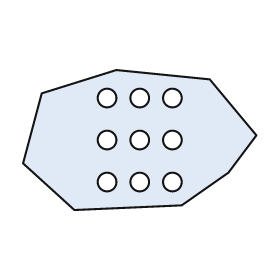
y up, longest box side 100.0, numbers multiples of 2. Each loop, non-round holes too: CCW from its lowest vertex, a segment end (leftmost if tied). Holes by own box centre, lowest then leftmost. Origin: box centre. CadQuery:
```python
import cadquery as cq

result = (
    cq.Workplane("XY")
    .moveTo(-28.0, -30.0)
    .lineTo(18.0, -28.0)
    .lineTo(38.0, -14.0)
    .lineTo(50.0, 2.0)
    .lineTo(30.0, 26.0)
    .lineTo(-10.0, 30.0)
    .lineTo(-42.0, 20.0)
    .lineTo(-50.0, -10.0)
    .close()
    .moveTo(-14.0, -18.0)
    .circle(4.0)
    .moveTo(0.0, -18.0)
    .circle(4.0)
    .moveTo(14.0, -18.0)
    .circle(4.0)
    .moveTo(-14.0, 0.0)
    .circle(4.0)
    .moveTo(0.0, 0.0)
    .circle(4.0)
    .moveTo(14.0, 0.0)
    .circle(4.0)
    .moveTo(-14.0, 18.0)
    .circle(4.0)
    .moveTo(0.0, 18.0)
    .circle(4.0)
    .moveTo(14.0, 18.0)
    .circle(4.0)
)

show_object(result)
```